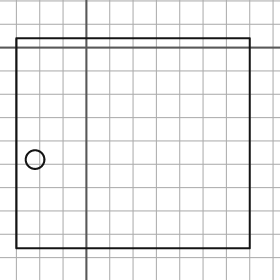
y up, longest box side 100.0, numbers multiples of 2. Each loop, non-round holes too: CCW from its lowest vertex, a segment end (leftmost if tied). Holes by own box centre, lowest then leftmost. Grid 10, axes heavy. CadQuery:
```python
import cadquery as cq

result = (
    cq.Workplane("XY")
    .moveTo(-30.0, -86.0)
    .lineTo(70.0, -86.0)
    .lineTo(70.0, 4.0)
    .lineTo(-30.0, 4.0)
    .close()
    .moveTo(-22.0, -48.0)
    .circle(4.0)
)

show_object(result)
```